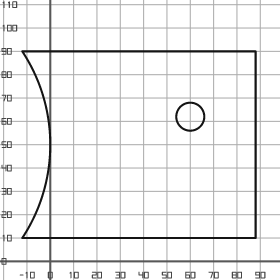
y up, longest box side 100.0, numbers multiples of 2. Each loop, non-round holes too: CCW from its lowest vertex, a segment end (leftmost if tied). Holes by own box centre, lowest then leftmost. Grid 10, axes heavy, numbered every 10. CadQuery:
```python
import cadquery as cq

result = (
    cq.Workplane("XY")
    .moveTo(-12.0, 10.0)
    .lineTo(88.0, 10.0)
    .lineTo(88.0, 90.0)
    .lineTo(-12.0, 90.0)
    .threePointArc((0.0, 50.0), (-12.0, 10.0))
    .close()
    .moveTo(60.0, 62.0)
    .circle(6.0)
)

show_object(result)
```